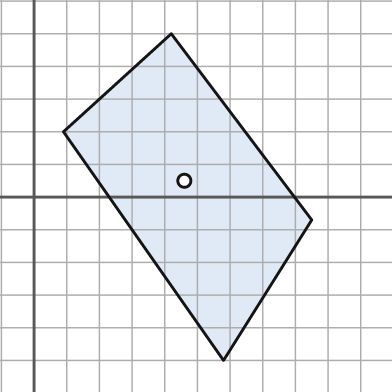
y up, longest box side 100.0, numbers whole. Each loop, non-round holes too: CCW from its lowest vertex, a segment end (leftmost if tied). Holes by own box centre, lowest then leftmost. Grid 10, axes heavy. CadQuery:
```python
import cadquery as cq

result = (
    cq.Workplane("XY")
    .moveTo(58.0, -50.0)
    .lineTo(85.0, -7.0)
    .lineTo(42.0, 50.0)
    .lineTo(9.0, 20.0)
    .close()
    .moveTo(46.0, 5.0)
    .circle(2.0)
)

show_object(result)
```